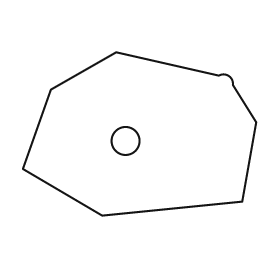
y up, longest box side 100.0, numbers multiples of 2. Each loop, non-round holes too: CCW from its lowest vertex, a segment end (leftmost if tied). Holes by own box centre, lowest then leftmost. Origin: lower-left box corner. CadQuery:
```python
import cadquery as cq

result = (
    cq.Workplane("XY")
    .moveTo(34.0, 0.0)
    .lineTo(94.0, 6.0)
    .lineTo(100.0, 40.0)
    .lineTo(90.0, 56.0)
    .threePointArc((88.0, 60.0), (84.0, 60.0))
    .lineTo(40.0, 70.0)
    .lineTo(12.0, 54.0)
    .lineTo(0.0, 20.0)
    .close()
    .moveTo(44.0, 32.0)
    .circle(6.0)
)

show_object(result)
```